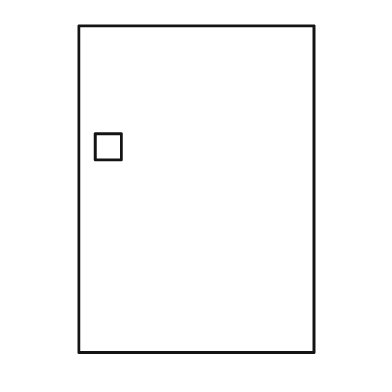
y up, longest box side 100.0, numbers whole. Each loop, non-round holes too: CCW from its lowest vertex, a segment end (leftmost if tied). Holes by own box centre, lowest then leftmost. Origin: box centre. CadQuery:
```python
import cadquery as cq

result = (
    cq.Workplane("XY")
    .moveTo(-36.0, -50.0)
    .lineTo(36.0, -50.0)
    .lineTo(36.0, 50.0)
    .lineTo(-36.0, 50.0)
    .close()
    .moveTo(-31.0, 9.0)
    .lineTo(-23.0, 9.0)
    .lineTo(-23.0, 17.0)
    .lineTo(-31.0, 17.0)
    .close()
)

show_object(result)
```